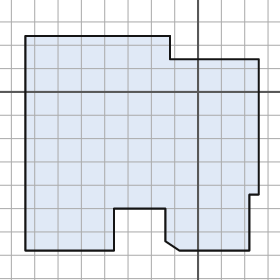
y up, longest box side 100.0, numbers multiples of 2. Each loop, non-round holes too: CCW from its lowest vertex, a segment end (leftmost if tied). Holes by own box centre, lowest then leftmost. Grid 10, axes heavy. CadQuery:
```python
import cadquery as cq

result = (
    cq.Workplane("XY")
    .moveTo(-74.0, -68.0)
    .lineTo(-36.0, -68.0)
    .lineTo(-36.0, -50.0)
    .lineTo(-14.0, -50.0)
    .lineTo(-14.0, -64.0)
    .lineTo(-8.0, -68.0)
    .lineTo(22.0, -68.0)
    .lineTo(22.0, -44.0)
    .lineTo(26.0, -44.0)
    .lineTo(26.0, 14.0)
    .lineTo(-12.0, 14.0)
    .lineTo(-12.0, 24.0)
    .lineTo(-74.0, 24.0)
    .close()
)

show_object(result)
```